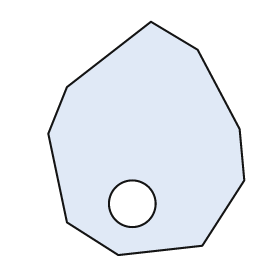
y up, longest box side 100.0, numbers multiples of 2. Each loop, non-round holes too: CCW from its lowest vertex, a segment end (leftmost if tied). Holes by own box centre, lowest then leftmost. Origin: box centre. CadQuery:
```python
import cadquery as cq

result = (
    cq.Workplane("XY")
    .moveTo(-12.0, -50.0)
    .lineTo(24.0, -46.0)
    .lineTo(42.0, -18.0)
    .lineTo(40.0, 4.0)
    .lineTo(22.0, 38.0)
    .lineTo(2.0, 50.0)
    .lineTo(-34.0, 22.0)
    .lineTo(-42.0, 2.0)
    .lineTo(-34.0, -36.0)
    .close()
    .moveTo(-6.0, -28.0)
    .circle(10.0)
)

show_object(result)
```